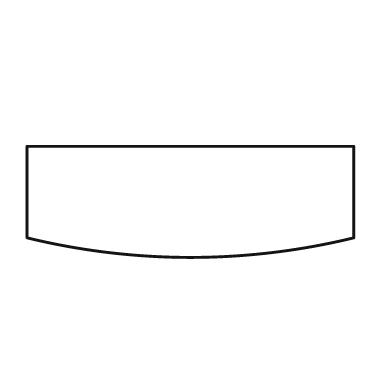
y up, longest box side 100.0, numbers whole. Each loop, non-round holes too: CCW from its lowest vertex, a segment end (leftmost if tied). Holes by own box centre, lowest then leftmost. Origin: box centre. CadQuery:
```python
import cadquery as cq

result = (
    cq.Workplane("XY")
    .moveTo(-50.0, -11.0)
    .threePointArc((0.0, -17.0), (50.0, -11.0))
    .lineTo(50.0, 17.0)
    .lineTo(-50.0, 17.0)
    .close()
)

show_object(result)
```